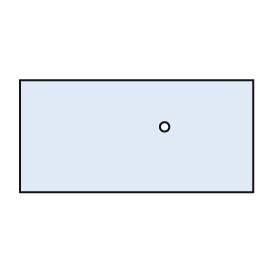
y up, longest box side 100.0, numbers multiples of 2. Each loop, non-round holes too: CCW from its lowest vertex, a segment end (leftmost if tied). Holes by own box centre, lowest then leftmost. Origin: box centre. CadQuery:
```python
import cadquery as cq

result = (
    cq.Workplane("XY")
    .moveTo(-50.0, -24.0)
    .lineTo(50.0, -24.0)
    .lineTo(50.0, 24.0)
    .lineTo(-50.0, 24.0)
    .close()
    .moveTo(12.0, 4.0)
    .circle(2.0)
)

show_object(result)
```